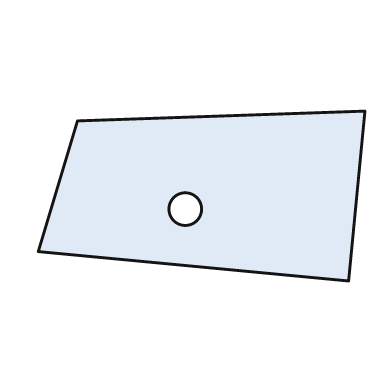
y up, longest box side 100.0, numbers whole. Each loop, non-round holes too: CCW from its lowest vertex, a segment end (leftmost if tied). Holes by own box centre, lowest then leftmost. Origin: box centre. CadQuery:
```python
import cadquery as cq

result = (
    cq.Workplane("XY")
    .moveTo(45.0, -26.0)
    .lineTo(50.0, 26.0)
    .lineTo(-38.0, 23.0)
    .lineTo(-50.0, -17.0)
    .close()
    .moveTo(-5.0, -4.0)
    .circle(5.0)
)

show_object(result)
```